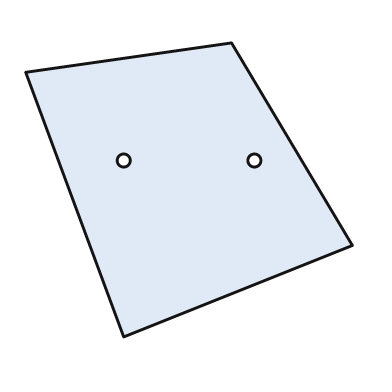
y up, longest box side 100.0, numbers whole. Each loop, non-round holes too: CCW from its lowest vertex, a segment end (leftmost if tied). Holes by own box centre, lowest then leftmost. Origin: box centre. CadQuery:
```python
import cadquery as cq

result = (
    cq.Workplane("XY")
    .moveTo(-20.0, -45.0)
    .lineTo(50.0, -17.0)
    .lineTo(13.0, 45.0)
    .lineTo(-50.0, 36.0)
    .close()
    .moveTo(-20.0, 9.0)
    .circle(2.0)
    .moveTo(20.0, 9.0)
    .circle(2.0)
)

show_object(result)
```